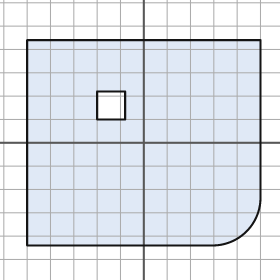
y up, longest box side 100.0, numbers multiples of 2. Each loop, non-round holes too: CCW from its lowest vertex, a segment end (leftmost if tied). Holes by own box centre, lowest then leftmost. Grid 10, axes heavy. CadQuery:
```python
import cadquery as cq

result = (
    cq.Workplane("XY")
    .moveTo(-50.0, -44.0)
    .lineTo(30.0, -44.0)
    .threePointArc((44.0, -38.0), (50.0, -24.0))
    .lineTo(50.0, 44.0)
    .lineTo(-50.0, 44.0)
    .close()
    .moveTo(-20.0, 10.0)
    .lineTo(-8.0, 10.0)
    .lineTo(-8.0, 22.0)
    .lineTo(-20.0, 22.0)
    .close()
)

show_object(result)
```